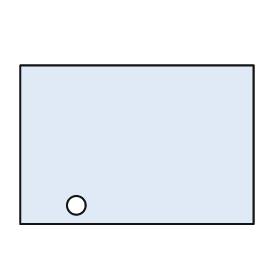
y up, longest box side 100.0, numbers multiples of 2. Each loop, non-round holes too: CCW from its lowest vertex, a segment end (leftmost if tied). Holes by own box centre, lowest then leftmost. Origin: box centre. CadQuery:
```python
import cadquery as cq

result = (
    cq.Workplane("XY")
    .moveTo(-50.0, -34.0)
    .lineTo(50.0, -34.0)
    .lineTo(50.0, 34.0)
    .lineTo(-50.0, 34.0)
    .close()
    .moveTo(-26.0, -26.0)
    .circle(4.0)
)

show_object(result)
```